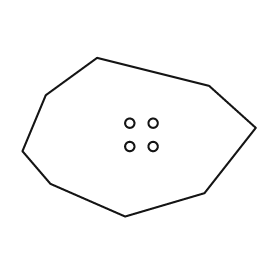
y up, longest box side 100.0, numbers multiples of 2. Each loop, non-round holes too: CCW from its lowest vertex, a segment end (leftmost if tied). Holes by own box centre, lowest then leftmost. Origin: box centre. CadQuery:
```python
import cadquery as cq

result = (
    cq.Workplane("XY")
    .moveTo(-6.0, -34.0)
    .lineTo(28.0, -24.0)
    .lineTo(50.0, 4.0)
    .lineTo(30.0, 22.0)
    .lineTo(-18.0, 34.0)
    .lineTo(-40.0, 18.0)
    .lineTo(-50.0, -6.0)
    .lineTo(-38.0, -20.0)
    .close()
    .moveTo(-4.0, -4.0)
    .circle(2.0)
    .moveTo(6.0, -4.0)
    .circle(2.0)
    .moveTo(-4.0, 6.0)
    .circle(2.0)
    .moveTo(6.0, 6.0)
    .circle(2.0)
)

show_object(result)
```